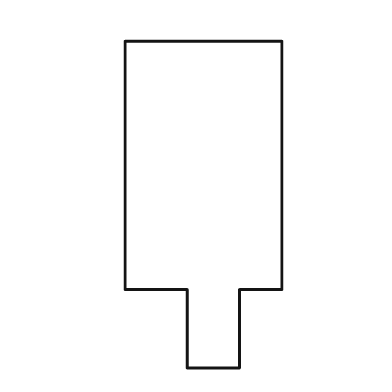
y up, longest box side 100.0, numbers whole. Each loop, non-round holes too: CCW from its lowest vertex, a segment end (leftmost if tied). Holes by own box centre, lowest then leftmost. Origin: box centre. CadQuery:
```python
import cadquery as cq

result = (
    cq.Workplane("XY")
    .moveTo(-5.0, -50.0)
    .lineTo(11.0, -50.0)
    .lineTo(11.0, -26.0)
    .lineTo(24.0, -26.0)
    .lineTo(24.0, 50.0)
    .lineTo(-24.0, 50.0)
    .lineTo(-24.0, -26.0)
    .lineTo(-5.0, -26.0)
    .close()
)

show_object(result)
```